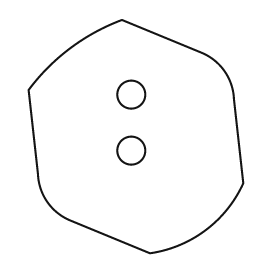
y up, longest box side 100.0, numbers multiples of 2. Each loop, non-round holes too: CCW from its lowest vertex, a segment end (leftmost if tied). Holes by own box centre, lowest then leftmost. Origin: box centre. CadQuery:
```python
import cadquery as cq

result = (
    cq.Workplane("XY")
    .moveTo(6.0, -50.0)
    .threePointArc((30.0, -40.0), (46.0, -20.0))
    .lineTo(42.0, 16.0)
    .threePointArc((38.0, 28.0), (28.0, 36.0))
    .lineTo(-6.0, 50.0)
    .threePointArc((-28.0, 38.0), (-46.0, 20.0))
    .lineTo(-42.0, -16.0)
    .threePointArc((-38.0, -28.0), (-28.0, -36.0))
    .close()
    .moveTo(-2.0, -6.0)
    .circle(6.0)
    .moveTo(-2.0, 18.0)
    .circle(6.0)
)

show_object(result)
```